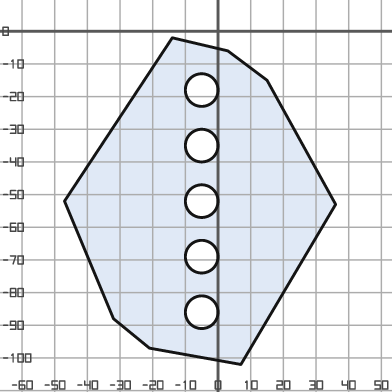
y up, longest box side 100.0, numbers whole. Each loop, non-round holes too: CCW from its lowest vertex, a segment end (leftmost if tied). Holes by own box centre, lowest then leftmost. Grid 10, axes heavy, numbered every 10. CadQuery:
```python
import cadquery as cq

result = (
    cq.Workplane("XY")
    .moveTo(7.0, -102.0)
    .lineTo(36.0, -53.0)
    .lineTo(15.0, -15.0)
    .lineTo(3.0, -6.0)
    .lineTo(-14.0, -2.0)
    .lineTo(-47.0, -52.0)
    .lineTo(-32.0, -88.0)
    .lineTo(-21.0, -97.0)
    .close()
    .moveTo(-5.0, -86.0)
    .circle(5.0)
    .moveTo(-5.0, -69.0)
    .circle(5.0)
    .moveTo(-5.0, -52.0)
    .circle(5.0)
    .moveTo(-5.0, -35.0)
    .circle(5.0)
    .moveTo(-5.0, -18.0)
    .circle(5.0)
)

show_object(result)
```